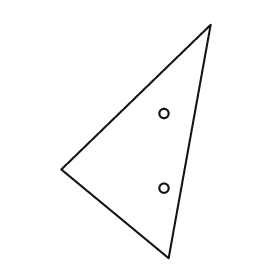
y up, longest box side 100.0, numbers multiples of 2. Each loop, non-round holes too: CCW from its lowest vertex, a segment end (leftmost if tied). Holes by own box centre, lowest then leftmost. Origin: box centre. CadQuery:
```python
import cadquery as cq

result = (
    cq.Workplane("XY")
    .moveTo(14.0, -50.0)
    .lineTo(32.0, 50.0)
    .lineTo(-32.0, -12.0)
    .close()
    .moveTo(12.0, -20.0)
    .circle(2.0)
    .moveTo(12.0, 12.0)
    .circle(2.0)
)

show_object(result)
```